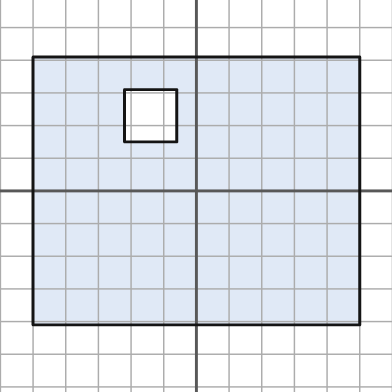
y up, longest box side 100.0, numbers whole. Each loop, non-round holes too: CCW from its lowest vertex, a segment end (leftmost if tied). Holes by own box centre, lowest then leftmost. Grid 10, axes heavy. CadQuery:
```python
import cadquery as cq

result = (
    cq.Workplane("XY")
    .moveTo(-50.0, -41.0)
    .lineTo(50.0, -41.0)
    .lineTo(50.0, 41.0)
    .lineTo(-50.0, 41.0)
    .close()
    .moveTo(-22.0, 15.0)
    .lineTo(-6.0, 15.0)
    .lineTo(-6.0, 31.0)
    .lineTo(-22.0, 31.0)
    .close()
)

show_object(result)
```